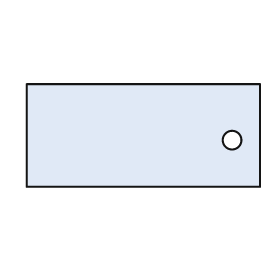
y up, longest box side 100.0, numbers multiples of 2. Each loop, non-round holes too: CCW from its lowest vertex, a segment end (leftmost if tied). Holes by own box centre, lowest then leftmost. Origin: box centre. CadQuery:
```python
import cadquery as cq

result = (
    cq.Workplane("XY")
    .moveTo(-50.0, -22.0)
    .lineTo(50.0, -22.0)
    .lineTo(50.0, 22.0)
    .lineTo(-50.0, 22.0)
    .close()
    .moveTo(38.0, -2.0)
    .circle(4.0)
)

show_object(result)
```